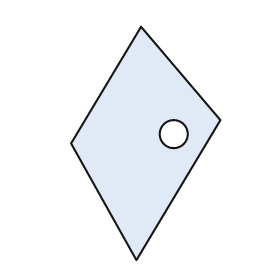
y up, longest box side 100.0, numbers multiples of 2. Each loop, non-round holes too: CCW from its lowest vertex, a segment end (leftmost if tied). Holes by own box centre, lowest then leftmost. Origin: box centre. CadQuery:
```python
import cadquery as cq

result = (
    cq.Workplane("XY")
    .moveTo(-4.0, -50.0)
    .lineTo(32.0, 10.0)
    .lineTo(-2.0, 50.0)
    .lineTo(-32.0, 0.0)
    .close()
    .moveTo(12.0, 4.0)
    .circle(6.0)
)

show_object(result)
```